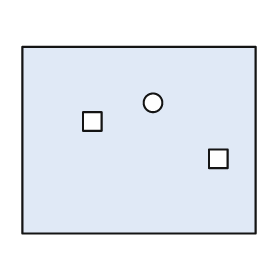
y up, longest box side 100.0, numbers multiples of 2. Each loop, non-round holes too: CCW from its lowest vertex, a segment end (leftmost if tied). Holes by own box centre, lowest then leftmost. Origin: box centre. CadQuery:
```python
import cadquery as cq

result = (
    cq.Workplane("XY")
    .moveTo(-50.0, -40.0)
    .lineTo(50.0, -40.0)
    .lineTo(50.0, 40.0)
    .lineTo(-50.0, 40.0)
    .close()
    .moveTo(30.0, -12.0)
    .lineTo(38.0, -12.0)
    .lineTo(38.0, -4.0)
    .lineTo(30.0, -4.0)
    .close()
    .moveTo(-24.0, 4.0)
    .lineTo(-16.0, 4.0)
    .lineTo(-16.0, 12.0)
    .lineTo(-24.0, 12.0)
    .close()
    .moveTo(6.0, 16.0)
    .circle(4.0)
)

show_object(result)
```